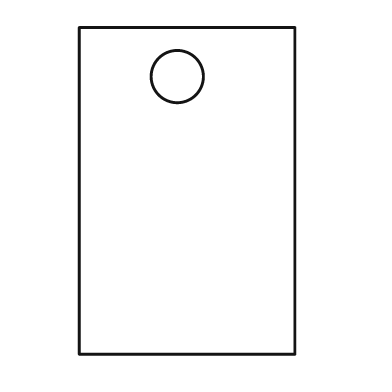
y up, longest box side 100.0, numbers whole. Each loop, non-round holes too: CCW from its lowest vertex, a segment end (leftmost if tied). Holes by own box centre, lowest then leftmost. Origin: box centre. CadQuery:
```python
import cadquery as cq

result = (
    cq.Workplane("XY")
    .moveTo(-33.0, -50.0)
    .lineTo(33.0, -50.0)
    .lineTo(33.0, 50.0)
    .lineTo(-33.0, 50.0)
    .close()
    .moveTo(-3.0, 35.0)
    .circle(8.0)
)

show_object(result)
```